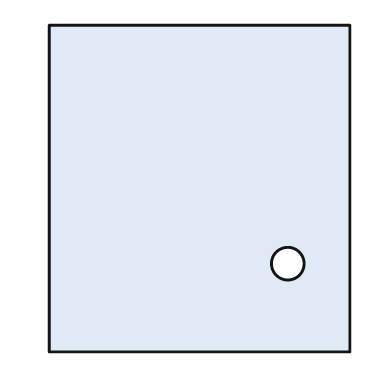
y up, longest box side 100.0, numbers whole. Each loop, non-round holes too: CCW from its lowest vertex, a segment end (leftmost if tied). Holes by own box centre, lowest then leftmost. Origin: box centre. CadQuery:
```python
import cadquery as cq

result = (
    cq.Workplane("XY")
    .moveTo(-46.0, -50.0)
    .lineTo(46.0, -50.0)
    .lineTo(46.0, 50.0)
    .lineTo(-46.0, 50.0)
    .close()
    .moveTo(27.0, -23.0)
    .circle(5.0)
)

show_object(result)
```